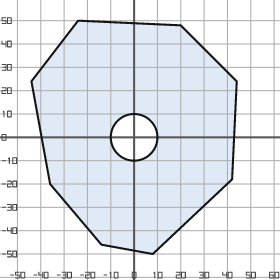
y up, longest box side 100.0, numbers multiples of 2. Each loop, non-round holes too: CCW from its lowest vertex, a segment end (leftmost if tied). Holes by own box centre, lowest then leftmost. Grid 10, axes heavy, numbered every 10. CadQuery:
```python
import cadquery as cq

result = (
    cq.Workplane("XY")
    .moveTo(8.0, -50.0)
    .lineTo(42.0, -18.0)
    .lineTo(44.0, 24.0)
    .lineTo(20.0, 48.0)
    .lineTo(-24.0, 50.0)
    .lineTo(-44.0, 24.0)
    .lineTo(-36.0, -20.0)
    .lineTo(-14.0, -46.0)
    .close()
    .moveTo(0.0, 0.0)
    .circle(10.0)
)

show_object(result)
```